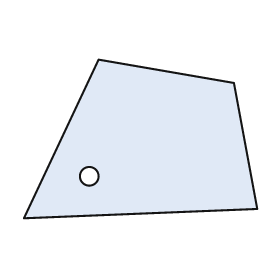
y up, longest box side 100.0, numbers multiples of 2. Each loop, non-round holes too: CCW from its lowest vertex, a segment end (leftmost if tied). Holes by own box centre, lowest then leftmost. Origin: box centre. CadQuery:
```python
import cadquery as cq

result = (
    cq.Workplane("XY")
    .moveTo(-50.0, -34.0)
    .lineTo(50.0, -30.0)
    .lineTo(40.0, 24.0)
    .lineTo(-18.0, 34.0)
    .close()
    .moveTo(-22.0, -16.0)
    .circle(4.0)
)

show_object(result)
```